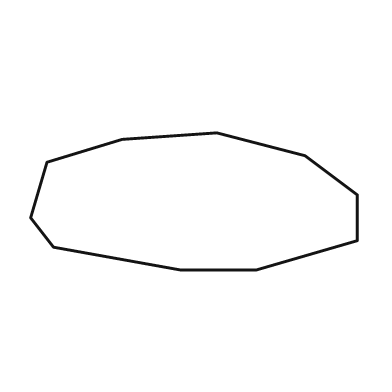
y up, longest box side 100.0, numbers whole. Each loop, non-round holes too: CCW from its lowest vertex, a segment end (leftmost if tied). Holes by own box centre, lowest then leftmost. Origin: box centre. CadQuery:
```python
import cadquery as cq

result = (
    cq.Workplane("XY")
    .moveTo(-4.0, -21.0)
    .lineTo(19.0, -21.0)
    .lineTo(50.0, -12.0)
    .lineTo(50.0, 2.0)
    .lineTo(34.0, 14.0)
    .lineTo(7.0, 21.0)
    .lineTo(-22.0, 19.0)
    .lineTo(-45.0, 12.0)
    .lineTo(-50.0, -5.0)
    .lineTo(-43.0, -14.0)
    .close()
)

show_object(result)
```